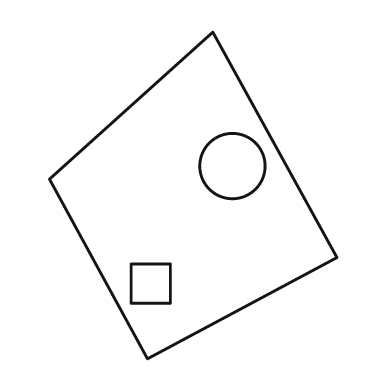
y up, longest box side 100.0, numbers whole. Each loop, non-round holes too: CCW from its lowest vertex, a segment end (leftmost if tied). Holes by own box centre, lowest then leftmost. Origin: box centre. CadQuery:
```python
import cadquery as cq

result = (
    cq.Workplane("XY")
    .moveTo(-14.0, -50.0)
    .lineTo(44.0, -19.0)
    .lineTo(6.0, 50.0)
    .lineTo(-44.0, 5.0)
    .close()
    .moveTo(-19.0, -33.0)
    .lineTo(-7.0, -33.0)
    .lineTo(-7.0, -21.0)
    .lineTo(-19.0, -21.0)
    .close()
    .moveTo(12.0, 9.0)
    .circle(10.0)
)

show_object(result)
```